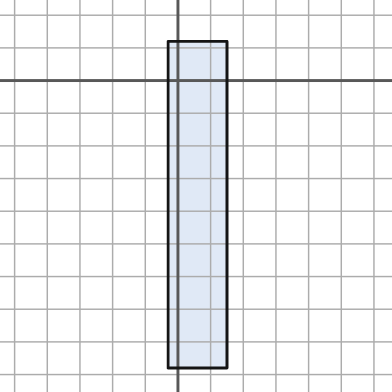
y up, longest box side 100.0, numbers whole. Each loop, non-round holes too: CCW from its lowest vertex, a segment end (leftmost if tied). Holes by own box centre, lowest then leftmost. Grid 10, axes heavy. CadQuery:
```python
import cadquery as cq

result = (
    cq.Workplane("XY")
    .moveTo(-3.0, -88.0)
    .lineTo(15.0, -88.0)
    .lineTo(15.0, 12.0)
    .lineTo(-3.0, 12.0)
    .close()
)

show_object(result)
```